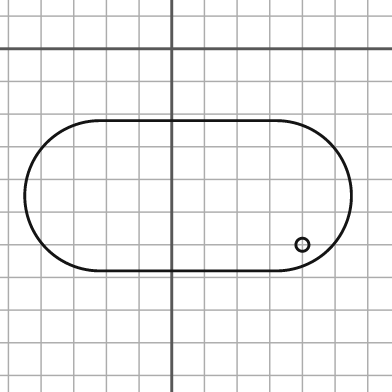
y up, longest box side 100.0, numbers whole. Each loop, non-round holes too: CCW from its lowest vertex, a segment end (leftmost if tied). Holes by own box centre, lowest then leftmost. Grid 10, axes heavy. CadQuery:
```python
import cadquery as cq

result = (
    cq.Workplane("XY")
    .moveTo(-22.0, -68.0)
    .lineTo(32.0, -68.0)
    .threePointArc((55.0, -45.0), (32.0, -22.0))
    .lineTo(-22.0, -22.0)
    .threePointArc((-45.0, -45.0), (-22.0, -68.0))
    .close()
    .moveTo(40.0, -60.0)
    .circle(2.0)
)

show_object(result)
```